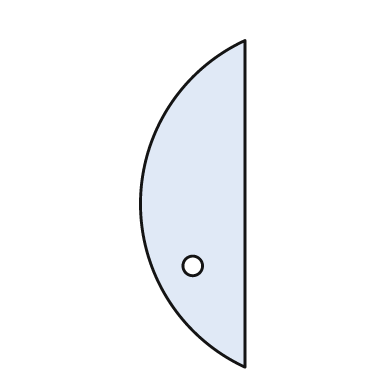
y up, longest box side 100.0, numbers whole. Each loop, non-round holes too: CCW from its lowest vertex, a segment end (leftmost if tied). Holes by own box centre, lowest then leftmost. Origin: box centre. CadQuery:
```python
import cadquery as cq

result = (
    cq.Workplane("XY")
    .moveTo(16.0, -50.0)
    .lineTo(16.0, 50.0)
    .threePointArc((-16.0, 0.0), (16.0, -50.0))
    .close()
    .moveTo(0.0, -19.0)
    .circle(3.0)
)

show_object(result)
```